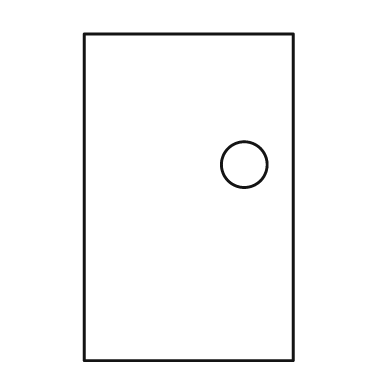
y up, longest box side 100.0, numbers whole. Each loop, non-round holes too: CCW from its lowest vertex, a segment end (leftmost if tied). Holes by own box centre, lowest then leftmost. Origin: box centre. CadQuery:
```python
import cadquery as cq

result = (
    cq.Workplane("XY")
    .moveTo(-32.0, -50.0)
    .lineTo(32.0, -50.0)
    .lineTo(32.0, 50.0)
    .lineTo(-32.0, 50.0)
    .close()
    .moveTo(17.0, 10.0)
    .circle(7.0)
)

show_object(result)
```